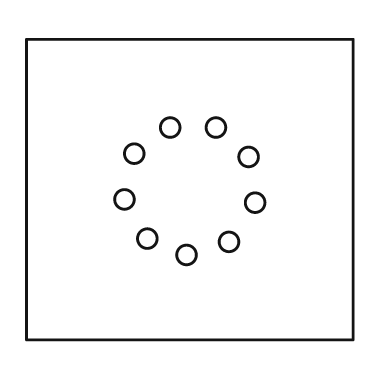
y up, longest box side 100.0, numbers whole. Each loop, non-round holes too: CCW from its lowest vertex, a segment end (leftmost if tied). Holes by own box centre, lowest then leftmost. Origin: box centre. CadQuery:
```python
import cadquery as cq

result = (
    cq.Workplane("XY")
    .moveTo(-50.0, -46.0)
    .lineTo(50.0, -46.0)
    .lineTo(50.0, 46.0)
    .lineTo(-50.0, 46.0)
    .close()
    .moveTo(-1.0, -20.0)
    .circle(3.0)
    .moveTo(12.0, -16.0)
    .circle(3.0)
    .moveTo(-13.0, -15.0)
    .circle(3.0)
    .moveTo(20.0, -4.0)
    .circle(3.0)
    .moveTo(-20.0, -3.0)
    .circle(3.0)
    .moveTo(18.0, 10.0)
    .circle(3.0)
    .moveTo(-17.0, 11.0)
    .circle(3.0)
    .moveTo(-6.0, 19.0)
    .circle(3.0)
    .moveTo(8.0, 19.0)
    .circle(3.0)
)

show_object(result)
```